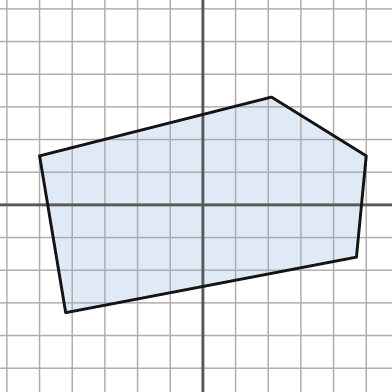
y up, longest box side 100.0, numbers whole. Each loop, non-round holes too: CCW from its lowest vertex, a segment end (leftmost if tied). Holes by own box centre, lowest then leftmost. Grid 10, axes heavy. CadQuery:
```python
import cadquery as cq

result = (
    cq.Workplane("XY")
    .moveTo(-42.0, -33.0)
    .lineTo(47.0, -16.0)
    .lineTo(50.0, 15.0)
    .lineTo(21.0, 33.0)
    .lineTo(-50.0, 15.0)
    .close()
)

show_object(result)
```